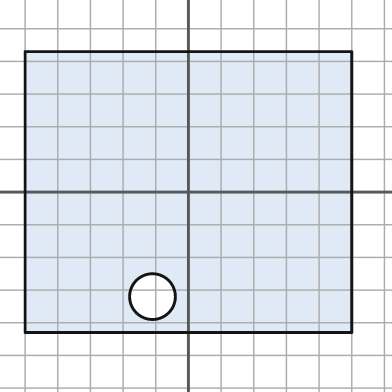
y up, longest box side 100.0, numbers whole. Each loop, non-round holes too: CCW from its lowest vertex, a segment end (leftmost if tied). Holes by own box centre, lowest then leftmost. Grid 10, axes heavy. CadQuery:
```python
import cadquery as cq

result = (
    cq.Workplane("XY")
    .moveTo(-50.0, -43.0)
    .lineTo(50.0, -43.0)
    .lineTo(50.0, 43.0)
    .lineTo(-50.0, 43.0)
    .close()
    .moveTo(-11.0, -32.0)
    .circle(7.0)
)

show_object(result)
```